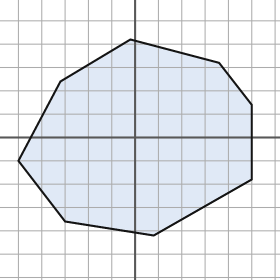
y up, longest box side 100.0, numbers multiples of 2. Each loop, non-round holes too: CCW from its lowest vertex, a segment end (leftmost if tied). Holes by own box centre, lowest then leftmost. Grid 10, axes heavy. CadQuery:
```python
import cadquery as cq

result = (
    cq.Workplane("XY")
    .moveTo(8.0, -42.0)
    .lineTo(50.0, -18.0)
    .lineTo(50.0, 14.0)
    .lineTo(36.0, 32.0)
    .lineTo(-2.0, 42.0)
    .lineTo(-32.0, 24.0)
    .lineTo(-50.0, -10.0)
    .lineTo(-30.0, -36.0)
    .close()
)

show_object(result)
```